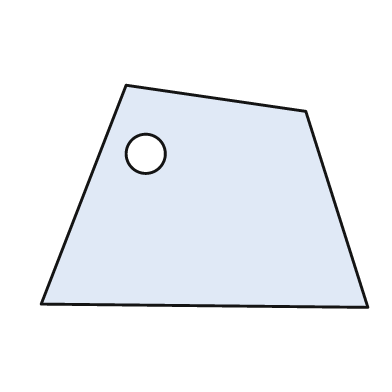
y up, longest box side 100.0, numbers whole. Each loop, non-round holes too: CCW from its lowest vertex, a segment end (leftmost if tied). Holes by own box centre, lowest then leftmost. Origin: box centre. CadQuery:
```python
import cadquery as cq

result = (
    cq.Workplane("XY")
    .moveTo(50.0, -34.0)
    .lineTo(31.0, 26.0)
    .lineTo(-24.0, 34.0)
    .lineTo(-50.0, -33.0)
    .close()
    .moveTo(-18.0, 13.0)
    .circle(6.0)
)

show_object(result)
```